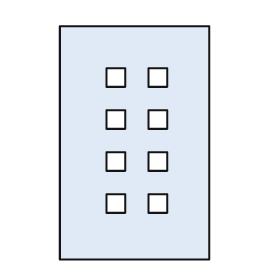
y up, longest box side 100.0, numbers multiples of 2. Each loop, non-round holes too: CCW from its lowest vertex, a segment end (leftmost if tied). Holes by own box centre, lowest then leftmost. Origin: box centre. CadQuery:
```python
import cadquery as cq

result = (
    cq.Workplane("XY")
    .moveTo(-32.0, -50.0)
    .lineTo(32.0, -50.0)
    .lineTo(32.0, 50.0)
    .lineTo(-32.0, 50.0)
    .close()
    .moveTo(-12.0, -30.0)
    .lineTo(-4.0, -30.0)
    .lineTo(-4.0, -22.0)
    .lineTo(-12.0, -22.0)
    .close()
    .moveTo(6.0, -30.0)
    .lineTo(14.0, -30.0)
    .lineTo(14.0, -22.0)
    .lineTo(6.0, -22.0)
    .close()
    .moveTo(-12.0, -12.0)
    .lineTo(-4.0, -12.0)
    .lineTo(-4.0, -4.0)
    .lineTo(-12.0, -4.0)
    .close()
    .moveTo(6.0, -12.0)
    .lineTo(14.0, -12.0)
    .lineTo(14.0, -4.0)
    .lineTo(6.0, -4.0)
    .close()
    .moveTo(-12.0, 6.0)
    .lineTo(-4.0, 6.0)
    .lineTo(-4.0, 14.0)
    .lineTo(-12.0, 14.0)
    .close()
    .moveTo(6.0, 6.0)
    .lineTo(14.0, 6.0)
    .lineTo(14.0, 14.0)
    .lineTo(6.0, 14.0)
    .close()
    .moveTo(-12.0, 24.0)
    .lineTo(-4.0, 24.0)
    .lineTo(-4.0, 32.0)
    .lineTo(-12.0, 32.0)
    .close()
    .moveTo(6.0, 24.0)
    .lineTo(14.0, 24.0)
    .lineTo(14.0, 32.0)
    .lineTo(6.0, 32.0)
    .close()
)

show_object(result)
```